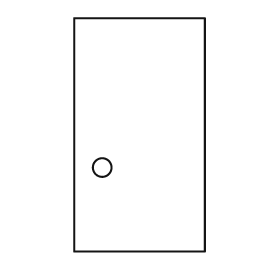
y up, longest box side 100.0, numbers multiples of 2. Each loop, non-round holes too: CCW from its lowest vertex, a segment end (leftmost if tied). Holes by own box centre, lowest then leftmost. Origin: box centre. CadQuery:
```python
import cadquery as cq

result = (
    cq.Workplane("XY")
    .moveTo(-28.0, -50.0)
    .lineTo(28.0, -50.0)
    .lineTo(28.0, 50.0)
    .lineTo(-28.0, 50.0)
    .close()
    .moveTo(-16.0, -14.0)
    .circle(4.0)
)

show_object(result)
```